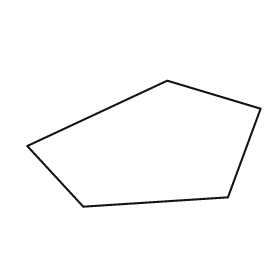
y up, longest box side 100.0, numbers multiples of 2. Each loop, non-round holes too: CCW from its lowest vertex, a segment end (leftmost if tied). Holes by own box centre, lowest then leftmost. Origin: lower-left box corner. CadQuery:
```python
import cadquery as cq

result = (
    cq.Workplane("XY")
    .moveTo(24.0, 0.0)
    .lineTo(86.0, 4.0)
    .lineTo(100.0, 42.0)
    .lineTo(60.0, 54.0)
    .lineTo(0.0, 26.0)
    .close()
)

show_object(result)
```